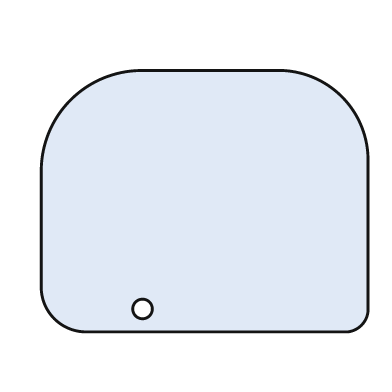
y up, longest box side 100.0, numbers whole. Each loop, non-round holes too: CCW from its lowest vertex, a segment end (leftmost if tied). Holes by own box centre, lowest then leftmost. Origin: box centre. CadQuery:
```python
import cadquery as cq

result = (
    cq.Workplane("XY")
    .moveTo(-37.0, -40.0)
    .lineTo(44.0, -40.0)
    .threePointArc((48.0, -38.0), (50.0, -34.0))
    .lineTo(50.0, 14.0)
    .threePointArc((42.0, 32.0), (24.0, 40.0))
    .lineTo(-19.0, 40.0)
    .threePointArc((-41.0, 31.0), (-50.0, 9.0))
    .lineTo(-50.0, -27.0)
    .threePointArc((-46.0, -36.0), (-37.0, -40.0))
    .close()
    .moveTo(-19.0, -33.0)
    .circle(3.0)
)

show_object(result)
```